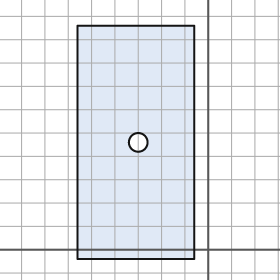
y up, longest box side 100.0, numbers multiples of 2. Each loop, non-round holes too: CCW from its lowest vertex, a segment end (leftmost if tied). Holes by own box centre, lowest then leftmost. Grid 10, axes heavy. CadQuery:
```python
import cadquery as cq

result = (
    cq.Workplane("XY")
    .moveTo(-56.0, -4.0)
    .lineTo(-6.0, -4.0)
    .lineTo(-6.0, 96.0)
    .lineTo(-56.0, 96.0)
    .close()
    .moveTo(-30.0, 46.0)
    .circle(4.0)
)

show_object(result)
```